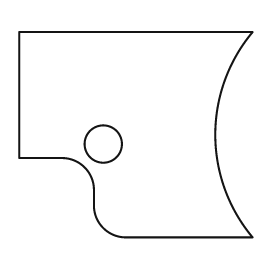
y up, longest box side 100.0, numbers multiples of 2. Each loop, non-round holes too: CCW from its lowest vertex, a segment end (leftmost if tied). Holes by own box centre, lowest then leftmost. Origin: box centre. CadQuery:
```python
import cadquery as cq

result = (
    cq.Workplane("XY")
    .moveTo(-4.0, -44.0)
    .lineTo(50.0, -44.0)
    .threePointArc((34.0, 0.0), (50.0, 44.0))
    .lineTo(-50.0, 44.0)
    .lineTo(-50.0, -10.0)
    .lineTo(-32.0, -10.0)
    .threePointArc((-22.0, -14.0), (-18.0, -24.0))
    .lineTo(-18.0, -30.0)
    .threePointArc((-14.0, -40.0), (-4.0, -44.0))
    .close()
    .moveTo(-14.0, -4.0)
    .circle(8.0)
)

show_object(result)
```